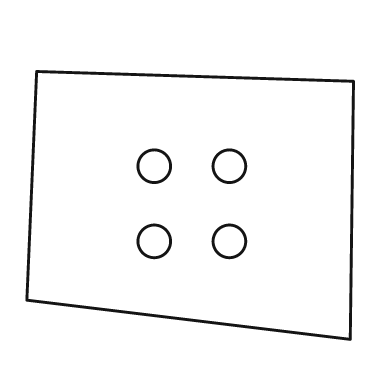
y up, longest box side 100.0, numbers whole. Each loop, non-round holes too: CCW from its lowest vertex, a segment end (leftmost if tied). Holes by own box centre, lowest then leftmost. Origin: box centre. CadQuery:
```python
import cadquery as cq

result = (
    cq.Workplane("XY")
    .moveTo(49.0, -41.0)
    .lineTo(50.0, 38.0)
    .lineTo(-47.0, 41.0)
    .lineTo(-50.0, -29.0)
    .close()
    .moveTo(-11.0, -11.0)
    .circle(5.0)
    .moveTo(12.0, -11.0)
    .circle(5.0)
    .moveTo(-11.0, 12.0)
    .circle(5.0)
    .moveTo(12.0, 12.0)
    .circle(5.0)
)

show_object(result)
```